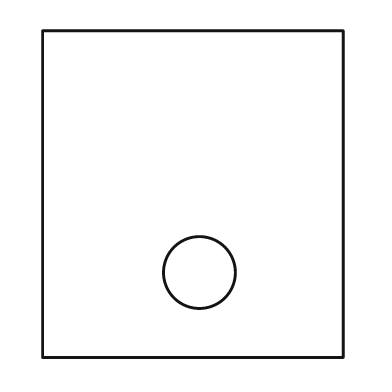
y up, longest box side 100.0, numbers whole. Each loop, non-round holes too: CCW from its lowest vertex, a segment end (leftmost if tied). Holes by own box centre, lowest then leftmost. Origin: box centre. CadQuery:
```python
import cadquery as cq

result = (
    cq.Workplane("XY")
    .moveTo(-46.0, -50.0)
    .lineTo(46.0, -50.0)
    .lineTo(46.0, 50.0)
    .lineTo(-46.0, 50.0)
    .close()
    .moveTo(2.0, -24.0)
    .circle(11.0)
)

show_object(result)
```